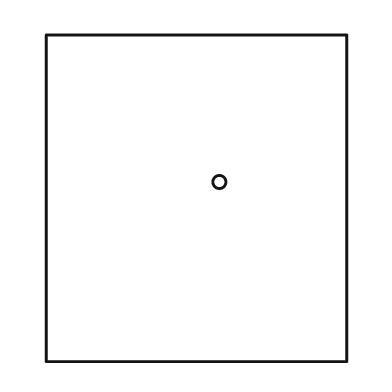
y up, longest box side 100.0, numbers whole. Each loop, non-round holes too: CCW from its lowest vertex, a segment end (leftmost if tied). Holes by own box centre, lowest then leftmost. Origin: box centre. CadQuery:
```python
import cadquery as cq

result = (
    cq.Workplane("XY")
    .moveTo(-46.0, -50.0)
    .lineTo(46.0, -50.0)
    .lineTo(46.0, 50.0)
    .lineTo(-46.0, 50.0)
    .close()
    .moveTo(7.0, 5.0)
    .circle(2.0)
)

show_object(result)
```